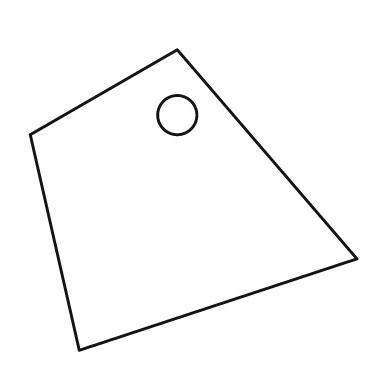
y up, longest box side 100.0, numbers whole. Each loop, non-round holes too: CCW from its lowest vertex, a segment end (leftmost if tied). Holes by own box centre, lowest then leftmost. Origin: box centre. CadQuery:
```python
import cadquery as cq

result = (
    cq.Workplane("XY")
    .moveTo(-35.0, -46.0)
    .lineTo(50.0, -18.0)
    .lineTo(-5.0, 46.0)
    .lineTo(-50.0, 20.0)
    .close()
    .moveTo(-5.0, 26.0)
    .circle(6.0)
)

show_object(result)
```